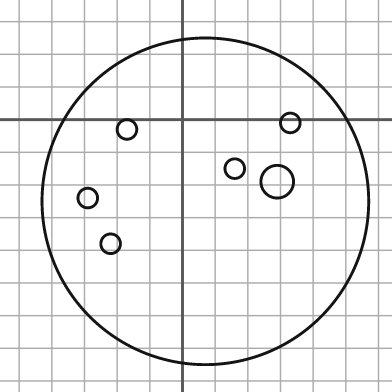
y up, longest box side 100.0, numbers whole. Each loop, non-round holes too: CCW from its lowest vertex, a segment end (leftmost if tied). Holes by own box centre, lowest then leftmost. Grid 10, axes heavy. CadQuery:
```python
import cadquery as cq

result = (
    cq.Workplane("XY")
    .moveTo(7.0, -25.0)
    .circle(50.0)
    .moveTo(-22.0, -38.0)
    .circle(3.0)
    .moveTo(-29.0, -24.0)
    .circle(3.0)
    .moveTo(29.0, -19.0)
    .circle(5.0)
    .moveTo(16.0, -15.0)
    .circle(3.0)
    .moveTo(-17.0, -3.0)
    .circle(3.0)
    .moveTo(33.0, -1.0)
    .circle(3.0)
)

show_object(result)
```